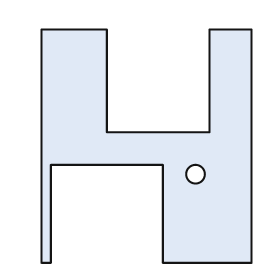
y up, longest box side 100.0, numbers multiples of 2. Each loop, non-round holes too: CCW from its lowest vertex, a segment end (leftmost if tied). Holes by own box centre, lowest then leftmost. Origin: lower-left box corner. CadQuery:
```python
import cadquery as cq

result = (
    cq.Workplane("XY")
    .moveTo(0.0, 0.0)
    .lineTo(4.0, 0.0)
    .lineTo(4.0, 42.0)
    .lineTo(52.0, 42.0)
    .lineTo(52.0, 0.0)
    .lineTo(90.0, 0.0)
    .lineTo(90.0, 100.0)
    .lineTo(72.0, 100.0)
    .lineTo(72.0, 56.0)
    .lineTo(28.0, 56.0)
    .lineTo(28.0, 100.0)
    .lineTo(0.0, 100.0)
    .close()
    .moveTo(66.0, 38.0)
    .circle(4.0)
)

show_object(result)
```